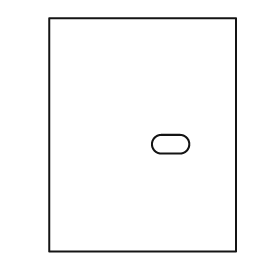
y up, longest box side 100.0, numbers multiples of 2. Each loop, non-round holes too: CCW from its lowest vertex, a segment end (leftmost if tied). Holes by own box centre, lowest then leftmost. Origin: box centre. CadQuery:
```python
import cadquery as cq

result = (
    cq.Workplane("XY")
    .moveTo(-40.0, -50.0)
    .lineTo(40.0, -50.0)
    .lineTo(40.0, 50.0)
    .lineTo(-40.0, 50.0)
    .close()
    .moveTo(8.0, -8.0)
    .lineTo(16.0, -8.0)
    .threePointArc((20.0, -4.0), (16.0, 0.0))
    .lineTo(8.0, 0.0)
    .threePointArc((4.0, -4.0), (8.0, -8.0))
    .close()
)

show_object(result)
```